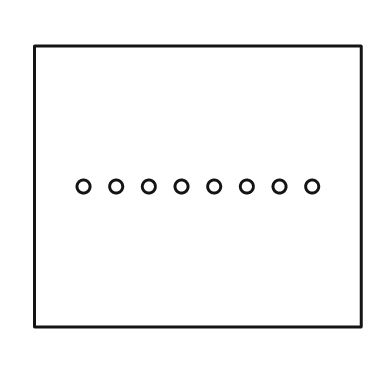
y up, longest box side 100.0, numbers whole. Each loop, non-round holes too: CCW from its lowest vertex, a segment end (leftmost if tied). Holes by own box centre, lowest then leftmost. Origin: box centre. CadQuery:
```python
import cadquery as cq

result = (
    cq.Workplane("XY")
    .moveTo(-50.0, -43.0)
    .lineTo(50.0, -43.0)
    .lineTo(50.0, 43.0)
    .lineTo(-50.0, 43.0)
    .close()
    .moveTo(-35.0, 0.0)
    .circle(2.0)
    .moveTo(-25.0, 0.0)
    .circle(2.0)
    .moveTo(-15.0, 0.0)
    .circle(2.0)
    .moveTo(-5.0, 0.0)
    .circle(2.0)
    .moveTo(5.0, 0.0)
    .circle(2.0)
    .moveTo(15.0, 0.0)
    .circle(2.0)
    .moveTo(25.0, 0.0)
    .circle(2.0)
    .moveTo(35.0, 0.0)
    .circle(2.0)
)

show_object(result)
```